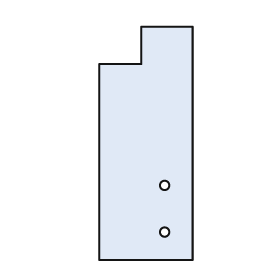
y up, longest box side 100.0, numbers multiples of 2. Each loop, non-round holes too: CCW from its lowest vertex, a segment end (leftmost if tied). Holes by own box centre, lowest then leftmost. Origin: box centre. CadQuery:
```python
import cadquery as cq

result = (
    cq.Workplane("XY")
    .moveTo(-20.0, -50.0)
    .lineTo(20.0, -50.0)
    .lineTo(20.0, 50.0)
    .lineTo(-2.0, 50.0)
    .lineTo(-2.0, 34.0)
    .lineTo(-20.0, 34.0)
    .close()
    .moveTo(8.0, -38.0)
    .circle(2.0)
    .moveTo(8.0, -18.0)
    .circle(2.0)
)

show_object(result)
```